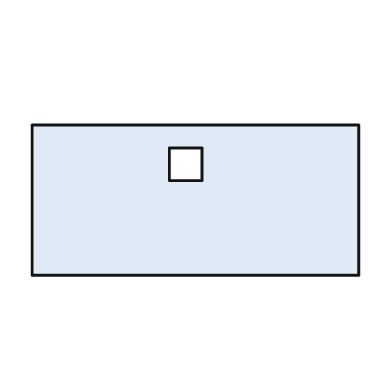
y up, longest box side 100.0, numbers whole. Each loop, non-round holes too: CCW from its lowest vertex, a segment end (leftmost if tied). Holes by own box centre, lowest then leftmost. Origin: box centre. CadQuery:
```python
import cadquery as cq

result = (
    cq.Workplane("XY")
    .moveTo(-50.0, -23.0)
    .lineTo(50.0, -23.0)
    .lineTo(50.0, 23.0)
    .lineTo(-50.0, 23.0)
    .close()
    .moveTo(-8.0, 6.0)
    .lineTo(2.0, 6.0)
    .lineTo(2.0, 16.0)
    .lineTo(-8.0, 16.0)
    .close()
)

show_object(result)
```